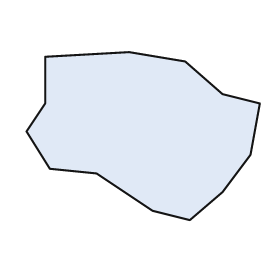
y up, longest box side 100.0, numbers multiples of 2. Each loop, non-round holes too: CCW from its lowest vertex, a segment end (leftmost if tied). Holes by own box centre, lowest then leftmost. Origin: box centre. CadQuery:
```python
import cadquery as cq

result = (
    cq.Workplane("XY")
    .moveTo(20.0, -36.0)
    .lineTo(34.0, -24.0)
    .lineTo(46.0, -8.0)
    .lineTo(50.0, 14.0)
    .lineTo(34.0, 18.0)
    .lineTo(18.0, 32.0)
    .lineTo(-6.0, 36.0)
    .lineTo(-42.0, 34.0)
    .lineTo(-42.0, 14.0)
    .lineTo(-50.0, 2.0)
    .lineTo(-40.0, -14.0)
    .lineTo(-20.0, -16.0)
    .lineTo(4.0, -32.0)
    .close()
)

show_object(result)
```